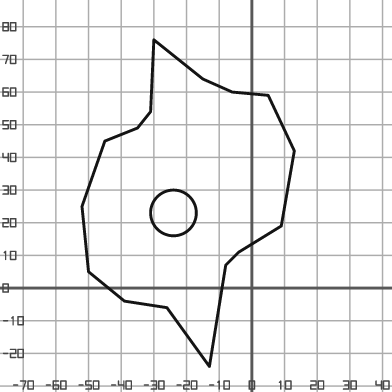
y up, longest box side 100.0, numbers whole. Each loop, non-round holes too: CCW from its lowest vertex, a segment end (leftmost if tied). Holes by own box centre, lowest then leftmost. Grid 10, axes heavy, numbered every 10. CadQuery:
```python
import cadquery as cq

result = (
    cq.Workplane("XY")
    .moveTo(-13.0, -24.0)
    .lineTo(-8.0, 7.0)
    .lineTo(-4.0, 11.0)
    .lineTo(9.0, 19.0)
    .lineTo(13.0, 42.0)
    .lineTo(5.0, 59.0)
    .lineTo(-6.0, 60.0)
    .lineTo(-15.0, 64.0)
    .lineTo(-30.0, 76.0)
    .lineTo(-31.0, 54.0)
    .lineTo(-35.0, 49.0)
    .lineTo(-45.0, 45.0)
    .lineTo(-52.0, 25.0)
    .lineTo(-50.0, 5.0)
    .lineTo(-39.0, -4.0)
    .lineTo(-26.0, -6.0)
    .close()
    .moveTo(-24.0, 23.0)
    .circle(7.0)
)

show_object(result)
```